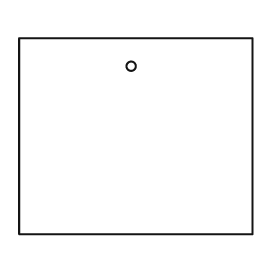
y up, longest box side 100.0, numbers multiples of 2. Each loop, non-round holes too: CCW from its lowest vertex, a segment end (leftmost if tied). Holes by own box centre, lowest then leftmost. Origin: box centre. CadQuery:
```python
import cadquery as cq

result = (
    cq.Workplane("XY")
    .moveTo(-50.0, -42.0)
    .lineTo(50.0, -42.0)
    .lineTo(50.0, 42.0)
    .lineTo(-50.0, 42.0)
    .close()
    .moveTo(-2.0, 30.0)
    .circle(2.0)
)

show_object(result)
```